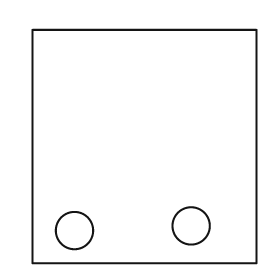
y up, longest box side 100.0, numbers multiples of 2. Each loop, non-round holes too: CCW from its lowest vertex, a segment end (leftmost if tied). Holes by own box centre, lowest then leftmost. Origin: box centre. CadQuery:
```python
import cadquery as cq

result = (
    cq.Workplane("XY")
    .moveTo(-48.0, -50.0)
    .lineTo(48.0, -50.0)
    .lineTo(48.0, 50.0)
    .lineTo(-48.0, 50.0)
    .close()
    .moveTo(-30.0, -36.0)
    .circle(8.0)
    .moveTo(20.0, -34.0)
    .circle(8.0)
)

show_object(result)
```